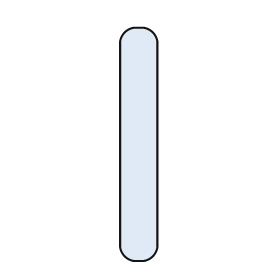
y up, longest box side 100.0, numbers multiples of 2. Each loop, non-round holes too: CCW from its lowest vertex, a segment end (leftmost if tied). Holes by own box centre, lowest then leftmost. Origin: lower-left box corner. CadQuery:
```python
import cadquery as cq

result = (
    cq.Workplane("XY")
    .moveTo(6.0, 0.0)
    .lineTo(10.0, 0.0)
    .threePointArc((14.0, 2.0), (16.0, 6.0))
    .lineTo(16.0, 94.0)
    .threePointArc((14.0, 98.0), (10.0, 100.0))
    .lineTo(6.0, 100.0)
    .threePointArc((2.0, 98.0), (0.0, 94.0))
    .lineTo(0.0, 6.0)
    .threePointArc((2.0, 2.0), (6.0, 0.0))
    .close()
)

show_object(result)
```